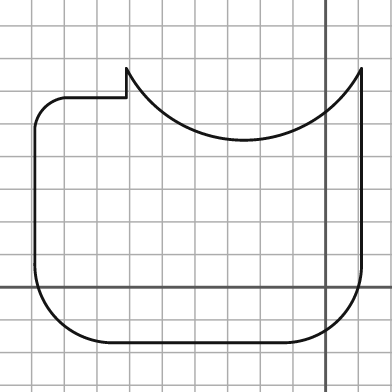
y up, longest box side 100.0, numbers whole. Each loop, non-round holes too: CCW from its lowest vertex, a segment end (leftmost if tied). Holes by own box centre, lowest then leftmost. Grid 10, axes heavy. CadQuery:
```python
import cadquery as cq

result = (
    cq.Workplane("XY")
    .moveTo(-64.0, -17.0)
    .lineTo(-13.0, -17.0)
    .threePointArc((4.0, -10.0), (11.0, 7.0))
    .lineTo(11.0, 67.0)
    .threePointArc((-25.0, 45.0), (-61.0, 67.0))
    .lineTo(-61.0, 58.0)
    .lineTo(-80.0, 58.0)
    .threePointArc((-86.0, 55.0), (-89.0, 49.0))
    .lineTo(-89.0, 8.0)
    .threePointArc((-82.0, -10.0), (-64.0, -17.0))
    .close()
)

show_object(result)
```